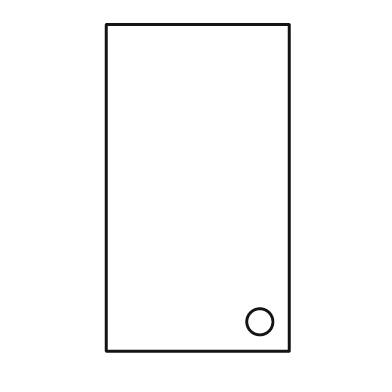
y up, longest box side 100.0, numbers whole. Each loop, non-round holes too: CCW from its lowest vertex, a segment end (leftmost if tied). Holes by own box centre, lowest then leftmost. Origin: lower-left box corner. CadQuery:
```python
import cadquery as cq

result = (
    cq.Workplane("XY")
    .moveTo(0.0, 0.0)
    .lineTo(56.0, 0.0)
    .lineTo(56.0, 100.0)
    .lineTo(0.0, 100.0)
    .close()
    .moveTo(47.0, 9.0)
    .circle(4.0)
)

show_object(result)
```